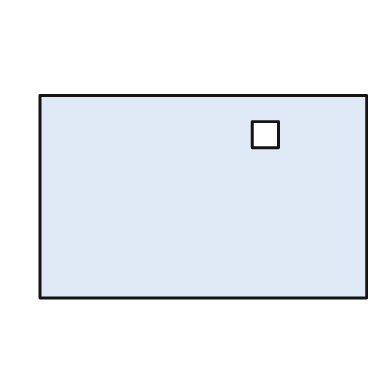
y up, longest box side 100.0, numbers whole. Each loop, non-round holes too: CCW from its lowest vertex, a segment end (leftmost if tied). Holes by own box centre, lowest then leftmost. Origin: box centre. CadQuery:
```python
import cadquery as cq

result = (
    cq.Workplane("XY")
    .moveTo(-50.0, -31.0)
    .lineTo(50.0, -31.0)
    .lineTo(50.0, 31.0)
    .lineTo(-50.0, 31.0)
    .close()
    .moveTo(15.0, 15.0)
    .lineTo(23.0, 15.0)
    .lineTo(23.0, 23.0)
    .lineTo(15.0, 23.0)
    .close()
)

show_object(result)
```